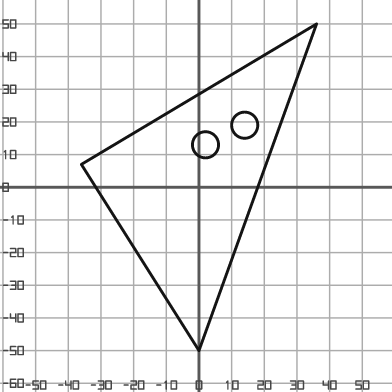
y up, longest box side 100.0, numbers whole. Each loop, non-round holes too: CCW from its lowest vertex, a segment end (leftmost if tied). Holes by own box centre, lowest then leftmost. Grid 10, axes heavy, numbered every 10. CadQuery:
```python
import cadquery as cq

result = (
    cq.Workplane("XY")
    .moveTo(0.0, -50.0)
    .lineTo(36.0, 50.0)
    .lineTo(-36.0, 7.0)
    .close()
    .moveTo(2.0, 13.0)
    .circle(4.0)
    .moveTo(14.0, 19.0)
    .circle(4.0)
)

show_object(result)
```